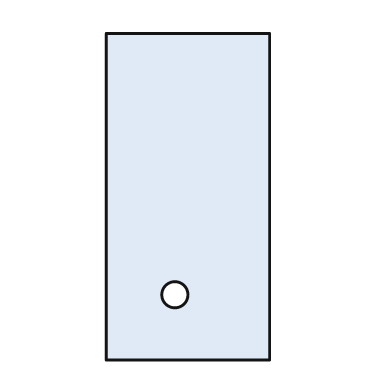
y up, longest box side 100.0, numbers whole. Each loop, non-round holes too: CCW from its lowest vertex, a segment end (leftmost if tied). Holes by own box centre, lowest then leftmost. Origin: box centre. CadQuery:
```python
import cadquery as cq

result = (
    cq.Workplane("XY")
    .moveTo(-25.0, -50.0)
    .lineTo(25.0, -50.0)
    .lineTo(25.0, 50.0)
    .lineTo(-25.0, 50.0)
    .close()
    .moveTo(-4.0, -30.0)
    .circle(4.0)
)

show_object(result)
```